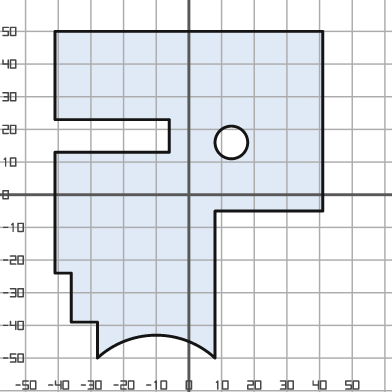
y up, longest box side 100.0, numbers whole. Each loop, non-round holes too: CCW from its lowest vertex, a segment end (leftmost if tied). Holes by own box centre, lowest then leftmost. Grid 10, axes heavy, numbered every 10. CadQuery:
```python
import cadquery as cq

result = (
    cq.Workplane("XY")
    .moveTo(-28.0, -50.0)
    .threePointArc((-10.0, -43.0), (8.0, -50.0))
    .lineTo(8.0, -5.0)
    .lineTo(41.0, -5.0)
    .lineTo(41.0, 50.0)
    .lineTo(-41.0, 50.0)
    .lineTo(-41.0, 23.0)
    .lineTo(-6.0, 23.0)
    .lineTo(-6.0, 13.0)
    .lineTo(-41.0, 13.0)
    .lineTo(-41.0, -24.0)
    .lineTo(-36.0, -24.0)
    .lineTo(-36.0, -39.0)
    .lineTo(-28.0, -39.0)
    .close()
    .moveTo(13.0, 16.0)
    .circle(5.0)
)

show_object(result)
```